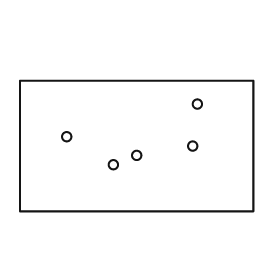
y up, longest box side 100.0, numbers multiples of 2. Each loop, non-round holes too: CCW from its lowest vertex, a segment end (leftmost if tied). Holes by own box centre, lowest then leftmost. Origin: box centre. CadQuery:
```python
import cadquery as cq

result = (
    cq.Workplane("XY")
    .moveTo(-50.0, -28.0)
    .lineTo(50.0, -28.0)
    .lineTo(50.0, 28.0)
    .lineTo(-50.0, 28.0)
    .close()
    .moveTo(-10.0, -8.0)
    .circle(2.0)
    .moveTo(0.0, -4.0)
    .circle(2.0)
    .moveTo(24.0, 0.0)
    .circle(2.0)
    .moveTo(-30.0, 4.0)
    .circle(2.0)
    .moveTo(26.0, 18.0)
    .circle(2.0)
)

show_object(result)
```